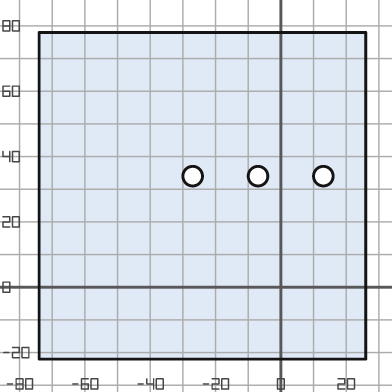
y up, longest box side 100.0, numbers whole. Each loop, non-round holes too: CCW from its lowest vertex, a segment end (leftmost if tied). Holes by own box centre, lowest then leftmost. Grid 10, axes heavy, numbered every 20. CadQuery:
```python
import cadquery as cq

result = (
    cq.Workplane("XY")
    .moveTo(-74.0, -22.0)
    .lineTo(26.0, -22.0)
    .lineTo(26.0, 78.0)
    .lineTo(-74.0, 78.0)
    .close()
    .moveTo(-27.0, 34.0)
    .circle(3.0)
    .moveTo(-7.0, 34.0)
    .circle(3.0)
    .moveTo(13.0, 34.0)
    .circle(3.0)
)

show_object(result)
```